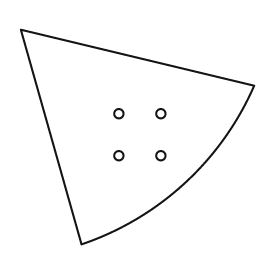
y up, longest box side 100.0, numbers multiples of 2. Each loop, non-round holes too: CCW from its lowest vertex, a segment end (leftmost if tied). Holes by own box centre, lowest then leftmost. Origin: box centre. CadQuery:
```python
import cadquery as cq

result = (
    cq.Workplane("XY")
    .moveTo(-24.0, -46.0)
    .threePointArc((20.0, -20.0), (50.0, 22.0))
    .lineTo(-50.0, 46.0)
    .close()
    .moveTo(-8.0, -8.0)
    .circle(2.0)
    .moveTo(10.0, -8.0)
    .circle(2.0)
    .moveTo(-8.0, 10.0)
    .circle(2.0)
    .moveTo(10.0, 10.0)
    .circle(2.0)
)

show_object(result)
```